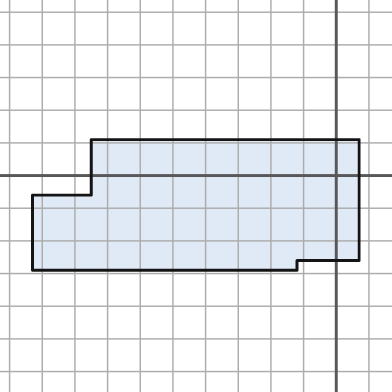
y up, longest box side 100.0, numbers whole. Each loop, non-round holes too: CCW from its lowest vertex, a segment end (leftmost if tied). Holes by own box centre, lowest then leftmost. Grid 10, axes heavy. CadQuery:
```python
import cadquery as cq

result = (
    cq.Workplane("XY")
    .moveTo(-93.0, -29.0)
    .lineTo(-12.0, -29.0)
    .lineTo(-12.0, -26.0)
    .lineTo(7.0, -26.0)
    .lineTo(7.0, 11.0)
    .lineTo(-75.0, 11.0)
    .lineTo(-75.0, -6.0)
    .lineTo(-93.0, -6.0)
    .close()
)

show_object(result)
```